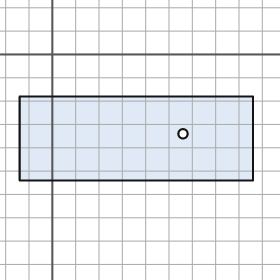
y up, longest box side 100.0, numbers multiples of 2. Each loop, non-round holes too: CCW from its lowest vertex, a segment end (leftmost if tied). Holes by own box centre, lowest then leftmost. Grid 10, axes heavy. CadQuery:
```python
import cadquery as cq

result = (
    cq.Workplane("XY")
    .moveTo(-14.0, -54.0)
    .lineTo(86.0, -54.0)
    .lineTo(86.0, -18.0)
    .lineTo(-14.0, -18.0)
    .close()
    .moveTo(56.0, -34.0)
    .circle(2.0)
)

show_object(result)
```